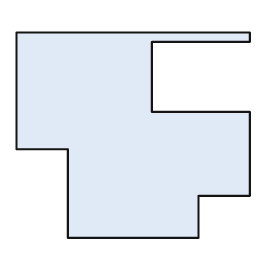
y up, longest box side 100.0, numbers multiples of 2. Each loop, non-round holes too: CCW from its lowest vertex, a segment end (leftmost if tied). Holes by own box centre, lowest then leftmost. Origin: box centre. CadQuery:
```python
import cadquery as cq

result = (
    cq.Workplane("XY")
    .moveTo(-28.0, -44.0)
    .lineTo(28.0, -44.0)
    .lineTo(28.0, -26.0)
    .lineTo(50.0, -26.0)
    .lineTo(50.0, 10.0)
    .lineTo(8.0, 10.0)
    .lineTo(8.0, 40.0)
    .lineTo(50.0, 40.0)
    .lineTo(50.0, 44.0)
    .lineTo(-50.0, 44.0)
    .lineTo(-50.0, -6.0)
    .lineTo(-28.0, -6.0)
    .close()
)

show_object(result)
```